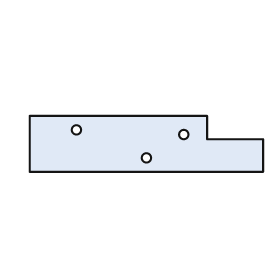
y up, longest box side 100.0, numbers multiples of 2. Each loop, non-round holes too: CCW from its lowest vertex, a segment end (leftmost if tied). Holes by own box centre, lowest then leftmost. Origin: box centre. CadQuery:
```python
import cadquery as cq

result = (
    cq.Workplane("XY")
    .moveTo(-50.0, -12.0)
    .lineTo(50.0, -12.0)
    .lineTo(50.0, 2.0)
    .lineTo(26.0, 2.0)
    .lineTo(26.0, 12.0)
    .lineTo(-50.0, 12.0)
    .close()
    .moveTo(0.0, -6.0)
    .circle(2.0)
    .moveTo(16.0, 4.0)
    .circle(2.0)
    .moveTo(-30.0, 6.0)
    .circle(2.0)
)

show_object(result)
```